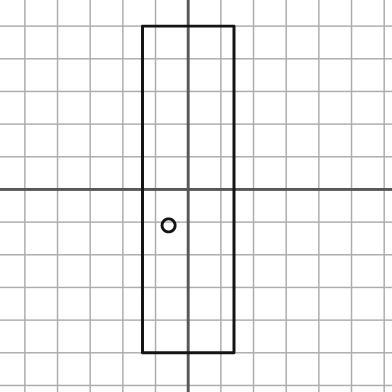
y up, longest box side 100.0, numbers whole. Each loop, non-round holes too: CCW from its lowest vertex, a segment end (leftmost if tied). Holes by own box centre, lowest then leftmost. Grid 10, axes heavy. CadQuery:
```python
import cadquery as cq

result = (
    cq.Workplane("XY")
    .moveTo(-14.0, -50.0)
    .lineTo(14.0, -50.0)
    .lineTo(14.0, 50.0)
    .lineTo(-14.0, 50.0)
    .close()
    .moveTo(-6.0, -11.0)
    .circle(2.0)
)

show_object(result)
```